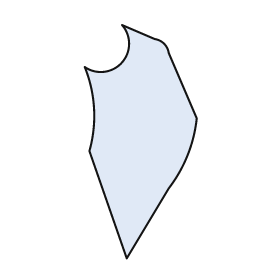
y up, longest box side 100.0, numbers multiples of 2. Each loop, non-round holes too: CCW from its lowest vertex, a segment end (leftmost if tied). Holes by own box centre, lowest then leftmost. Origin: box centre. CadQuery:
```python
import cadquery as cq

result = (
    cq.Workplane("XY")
    .moveTo(-6.0, -50.0)
    .lineTo(12.0, -20.0)
    .threePointArc((20.0, -6.0), (24.0, 10.0))
    .lineTo(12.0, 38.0)
    .threePointArc((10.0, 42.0), (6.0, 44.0))
    .lineTo(-8.0, 50.0)
    .threePointArc((-8.0, 34.0), (-24.0, 32.0))
    .threePointArc((-20.0, 14.0), (-22.0, -4.0))
    .close()
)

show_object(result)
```